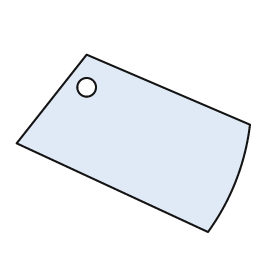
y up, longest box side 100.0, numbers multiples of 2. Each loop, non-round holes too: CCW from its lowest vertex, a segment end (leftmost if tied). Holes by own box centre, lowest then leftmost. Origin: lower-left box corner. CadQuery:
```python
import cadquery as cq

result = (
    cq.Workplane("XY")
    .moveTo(82.0, 0.0)
    .threePointArc((94.0, 22.0), (100.0, 46.0))
    .lineTo(30.0, 76.0)
    .lineTo(0.0, 38.0)
    .close()
    .moveTo(30.0, 62.0)
    .circle(4.0)
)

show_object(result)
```